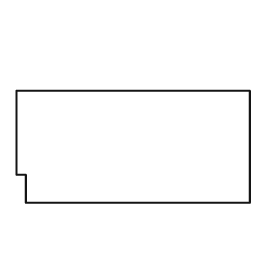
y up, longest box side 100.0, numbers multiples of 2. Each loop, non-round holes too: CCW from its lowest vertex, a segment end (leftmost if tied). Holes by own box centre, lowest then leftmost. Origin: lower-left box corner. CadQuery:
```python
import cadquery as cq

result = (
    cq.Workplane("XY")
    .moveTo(4.0, 0.0)
    .lineTo(100.0, 0.0)
    .lineTo(100.0, 48.0)
    .lineTo(0.0, 48.0)
    .lineTo(0.0, 12.0)
    .lineTo(4.0, 12.0)
    .close()
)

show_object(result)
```